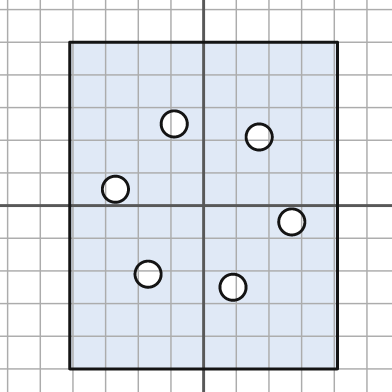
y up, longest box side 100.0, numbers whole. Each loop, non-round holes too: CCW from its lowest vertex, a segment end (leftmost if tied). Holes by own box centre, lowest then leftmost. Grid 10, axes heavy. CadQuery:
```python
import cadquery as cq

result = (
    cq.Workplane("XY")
    .moveTo(-41.0, -50.0)
    .lineTo(41.0, -50.0)
    .lineTo(41.0, 50.0)
    .lineTo(-41.0, 50.0)
    .close()
    .moveTo(9.0, -25.0)
    .circle(4.0)
    .moveTo(-17.0, -21.0)
    .circle(4.0)
    .moveTo(27.0, -5.0)
    .circle(4.0)
    .moveTo(-27.0, 5.0)
    .circle(4.0)
    .moveTo(17.0, 21.0)
    .circle(4.0)
    .moveTo(-9.0, 25.0)
    .circle(4.0)
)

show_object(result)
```